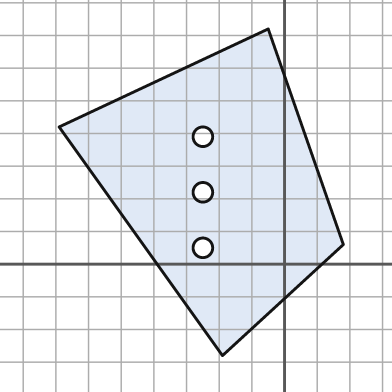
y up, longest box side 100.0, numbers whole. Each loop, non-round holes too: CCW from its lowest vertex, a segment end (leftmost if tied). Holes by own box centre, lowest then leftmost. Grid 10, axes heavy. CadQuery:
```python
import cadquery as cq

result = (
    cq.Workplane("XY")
    .moveTo(-19.0, -28.0)
    .lineTo(18.0, 6.0)
    .lineTo(-5.0, 72.0)
    .lineTo(-69.0, 42.0)
    .close()
    .moveTo(-25.0, 5.0)
    .circle(3.0)
    .moveTo(-25.0, 22.0)
    .circle(3.0)
    .moveTo(-25.0, 39.0)
    .circle(3.0)
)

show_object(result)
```